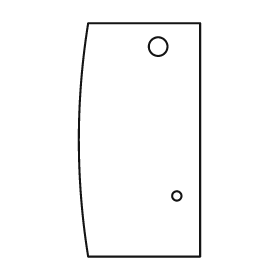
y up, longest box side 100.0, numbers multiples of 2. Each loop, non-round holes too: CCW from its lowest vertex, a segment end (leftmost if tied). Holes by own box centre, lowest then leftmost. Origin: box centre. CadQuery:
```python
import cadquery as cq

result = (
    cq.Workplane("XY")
    .moveTo(-22.0, -50.0)
    .lineTo(26.0, -50.0)
    .lineTo(26.0, 50.0)
    .lineTo(-22.0, 50.0)
    .threePointArc((-26.0, 0.0), (-22.0, -50.0))
    .close()
    .moveTo(16.0, -24.0)
    .circle(2.0)
    .moveTo(8.0, 40.0)
    .circle(4.0)
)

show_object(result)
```